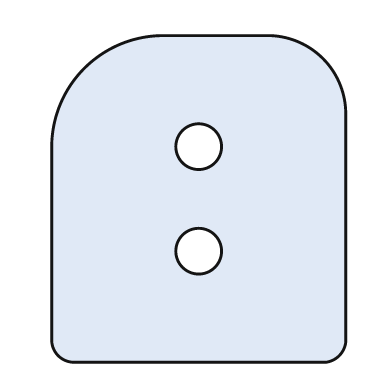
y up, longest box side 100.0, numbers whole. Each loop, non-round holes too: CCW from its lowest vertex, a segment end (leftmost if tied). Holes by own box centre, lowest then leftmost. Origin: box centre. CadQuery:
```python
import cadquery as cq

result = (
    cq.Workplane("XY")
    .moveTo(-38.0, -50.0)
    .lineTo(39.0, -50.0)
    .threePointArc((43.0, -48.0), (45.0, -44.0))
    .lineTo(45.0, 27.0)
    .threePointArc((38.0, 43.0), (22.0, 50.0))
    .lineTo(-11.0, 50.0)
    .threePointArc((-35.0, 40.0), (-45.0, 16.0))
    .lineTo(-45.0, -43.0)
    .threePointArc((-43.0, -48.0), (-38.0, -50.0))
    .close()
    .moveTo(0.0, -16.0)
    .circle(7.0)
    .moveTo(0.0, 16.0)
    .circle(7.0)
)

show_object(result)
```